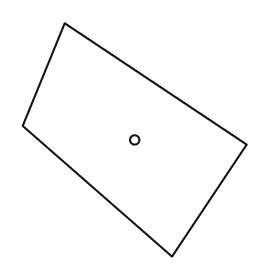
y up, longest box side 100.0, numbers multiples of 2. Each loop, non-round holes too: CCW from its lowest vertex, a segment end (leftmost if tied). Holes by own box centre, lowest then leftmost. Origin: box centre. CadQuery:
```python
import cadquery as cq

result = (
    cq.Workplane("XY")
    .moveTo(16.0, -50.0)
    .lineTo(48.0, -2.0)
    .lineTo(-30.0, 50.0)
    .lineTo(-48.0, 6.0)
    .close()
    .moveTo(0.0, 0.0)
    .circle(2.0)
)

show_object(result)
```